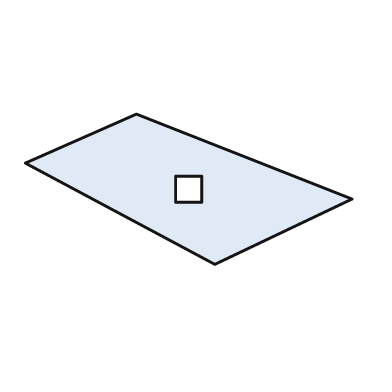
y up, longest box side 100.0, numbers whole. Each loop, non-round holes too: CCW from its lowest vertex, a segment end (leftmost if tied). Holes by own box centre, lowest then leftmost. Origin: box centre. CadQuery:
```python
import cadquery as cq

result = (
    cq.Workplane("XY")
    .moveTo(8.0, -23.0)
    .lineTo(50.0, -3.0)
    .lineTo(-16.0, 23.0)
    .lineTo(-50.0, 8.0)
    .close()
    .moveTo(-4.0, -4.0)
    .lineTo(4.0, -4.0)
    .lineTo(4.0, 4.0)
    .lineTo(-4.0, 4.0)
    .close()
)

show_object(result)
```